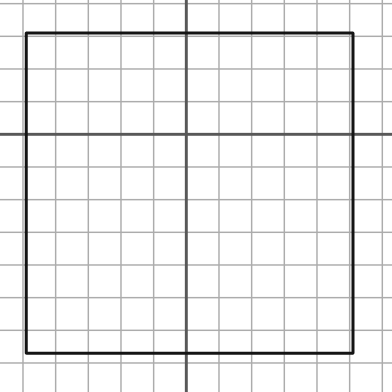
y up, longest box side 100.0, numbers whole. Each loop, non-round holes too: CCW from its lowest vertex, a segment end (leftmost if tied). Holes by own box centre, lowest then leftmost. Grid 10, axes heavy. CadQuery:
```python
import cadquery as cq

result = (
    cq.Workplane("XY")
    .moveTo(-49.0, -67.0)
    .lineTo(51.0, -67.0)
    .lineTo(51.0, 31.0)
    .lineTo(-49.0, 31.0)
    .close()
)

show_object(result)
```